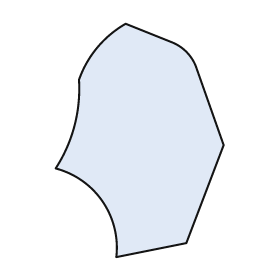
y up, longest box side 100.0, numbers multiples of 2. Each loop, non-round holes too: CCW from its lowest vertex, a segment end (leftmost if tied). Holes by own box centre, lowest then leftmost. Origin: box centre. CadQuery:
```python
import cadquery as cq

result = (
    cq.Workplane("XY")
    .moveTo(-10.0, -50.0)
    .lineTo(20.0, -44.0)
    .lineTo(36.0, -2.0)
    .lineTo(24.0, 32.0)
    .threePointArc((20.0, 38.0), (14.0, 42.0))
    .lineTo(-6.0, 50.0)
    .threePointArc((-18.0, 40.0), (-26.0, 26.0))
    .threePointArc((-28.0, 6.0), (-36.0, -12.0))
    .threePointArc((-16.0, -26.0), (-10.0, -50.0))
    .close()
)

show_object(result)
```